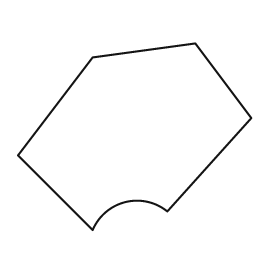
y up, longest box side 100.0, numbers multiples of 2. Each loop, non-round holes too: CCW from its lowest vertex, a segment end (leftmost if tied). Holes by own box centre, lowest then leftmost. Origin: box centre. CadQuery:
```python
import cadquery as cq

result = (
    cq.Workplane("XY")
    .moveTo(-18.0, -40.0)
    .threePointArc((-4.0, -28.0), (14.0, -32.0))
    .lineTo(50.0, 8.0)
    .lineTo(26.0, 40.0)
    .lineTo(-18.0, 34.0)
    .lineTo(-50.0, -8.0)
    .close()
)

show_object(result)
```